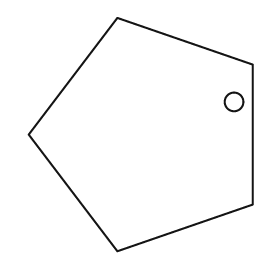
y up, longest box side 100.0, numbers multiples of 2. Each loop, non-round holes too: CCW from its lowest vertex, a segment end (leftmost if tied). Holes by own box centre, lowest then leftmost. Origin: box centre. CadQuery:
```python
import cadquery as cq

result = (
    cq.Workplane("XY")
    .moveTo(-10.0, -50.0)
    .lineTo(48.0, -30.0)
    .lineTo(48.0, 30.0)
    .lineTo(-10.0, 50.0)
    .lineTo(-48.0, 0.0)
    .close()
    .moveTo(40.0, 14.0)
    .circle(4.0)
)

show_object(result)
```